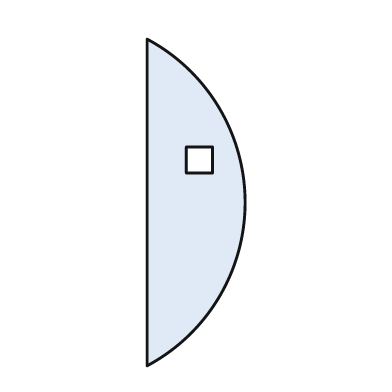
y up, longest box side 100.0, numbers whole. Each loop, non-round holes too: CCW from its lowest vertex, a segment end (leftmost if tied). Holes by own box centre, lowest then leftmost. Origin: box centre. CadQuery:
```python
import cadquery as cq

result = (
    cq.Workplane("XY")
    .moveTo(-15.0, -50.0)
    .threePointArc((15.0, 0.0), (-15.0, 50.0))
    .close()
    .moveTo(-3.0, 9.0)
    .lineTo(5.0, 9.0)
    .lineTo(5.0, 17.0)
    .lineTo(-3.0, 17.0)
    .close()
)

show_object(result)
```